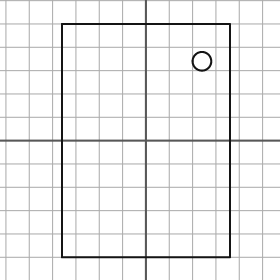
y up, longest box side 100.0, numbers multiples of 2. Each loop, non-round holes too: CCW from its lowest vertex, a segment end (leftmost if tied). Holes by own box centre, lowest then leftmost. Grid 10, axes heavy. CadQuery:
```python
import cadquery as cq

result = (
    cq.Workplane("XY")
    .moveTo(-36.0, -50.0)
    .lineTo(36.0, -50.0)
    .lineTo(36.0, 50.0)
    .lineTo(-36.0, 50.0)
    .close()
    .moveTo(24.0, 34.0)
    .circle(4.0)
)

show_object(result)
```